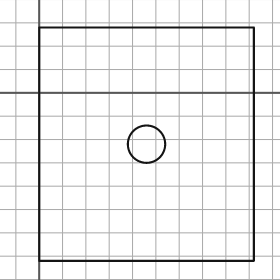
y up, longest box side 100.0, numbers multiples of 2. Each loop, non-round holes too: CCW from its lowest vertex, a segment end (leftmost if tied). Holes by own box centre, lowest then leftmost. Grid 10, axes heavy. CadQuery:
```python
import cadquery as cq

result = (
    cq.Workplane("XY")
    .moveTo(0.0, -72.0)
    .lineTo(92.0, -72.0)
    .lineTo(92.0, 28.0)
    .lineTo(0.0, 28.0)
    .close()
    .moveTo(46.0, -22.0)
    .circle(8.0)
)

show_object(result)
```